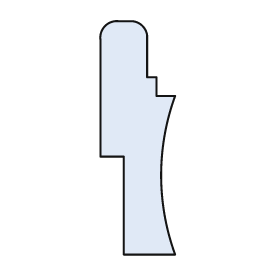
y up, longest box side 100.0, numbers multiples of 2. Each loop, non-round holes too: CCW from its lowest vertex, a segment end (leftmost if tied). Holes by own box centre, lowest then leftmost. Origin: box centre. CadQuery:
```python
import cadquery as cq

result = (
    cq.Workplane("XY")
    .moveTo(-6.0, -50.0)
    .lineTo(16.0, -50.0)
    .threePointArc((10.0, -16.0), (16.0, 18.0))
    .lineTo(8.0, 18.0)
    .lineTo(8.0, 26.0)
    .lineTo(4.0, 26.0)
    .lineTo(4.0, 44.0)
    .threePointArc((2.0, 48.0), (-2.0, 50.0))
    .lineTo(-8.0, 50.0)
    .threePointArc((-14.0, 48.0), (-16.0, 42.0))
    .lineTo(-16.0, -8.0)
    .lineTo(-6.0, -8.0)
    .close()
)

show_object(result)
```